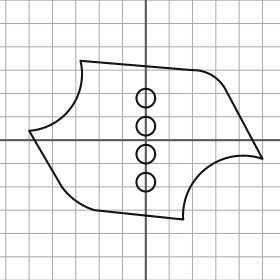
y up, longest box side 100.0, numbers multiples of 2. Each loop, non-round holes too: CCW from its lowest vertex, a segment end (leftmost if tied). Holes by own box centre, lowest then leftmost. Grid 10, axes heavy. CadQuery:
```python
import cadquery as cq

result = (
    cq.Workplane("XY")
    .moveTo(16.0, -34.0)
    .threePointArc((26.0, -12.0), (50.0, -8.0))
    .lineTo(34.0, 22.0)
    .threePointArc((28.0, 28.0), (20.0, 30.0))
    .lineTo(-28.0, 34.0)
    .threePointArc((-32.0, 14.0), (-50.0, 4.0))
    .lineTo(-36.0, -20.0)
    .threePointArc((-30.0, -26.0), (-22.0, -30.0))
    .close()
    .moveTo(0.0, -18.0)
    .circle(4.0)
    .moveTo(0.0, -6.0)
    .circle(4.0)
    .moveTo(0.0, 6.0)
    .circle(4.0)
    .moveTo(0.0, 18.0)
    .circle(4.0)
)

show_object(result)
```